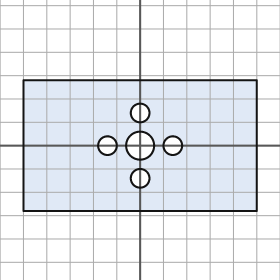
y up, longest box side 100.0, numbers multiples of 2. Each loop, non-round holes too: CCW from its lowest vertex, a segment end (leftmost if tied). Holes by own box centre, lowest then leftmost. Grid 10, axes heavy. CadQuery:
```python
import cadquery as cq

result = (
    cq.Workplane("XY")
    .moveTo(-50.0, -28.0)
    .lineTo(50.0, -28.0)
    .lineTo(50.0, 28.0)
    .lineTo(-50.0, 28.0)
    .close()
    .moveTo(0.0, -14.0)
    .circle(4.0)
    .moveTo(-14.0, 0.0)
    .circle(4.0)
    .moveTo(0.0, 0.0)
    .circle(6.0)
    .moveTo(14.0, 0.0)
    .circle(4.0)
    .moveTo(0.0, 14.0)
    .circle(4.0)
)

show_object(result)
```